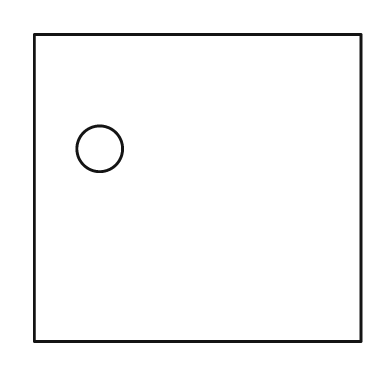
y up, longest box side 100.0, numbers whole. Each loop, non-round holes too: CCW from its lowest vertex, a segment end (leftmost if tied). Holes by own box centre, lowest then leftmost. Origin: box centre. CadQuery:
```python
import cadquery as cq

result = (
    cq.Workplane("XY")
    .moveTo(-50.0, -47.0)
    .lineTo(50.0, -47.0)
    .lineTo(50.0, 47.0)
    .lineTo(-50.0, 47.0)
    .close()
    .moveTo(-30.0, 12.0)
    .circle(7.0)
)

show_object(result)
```